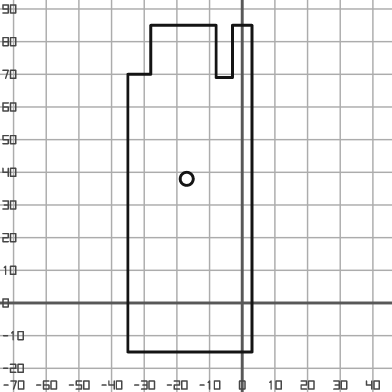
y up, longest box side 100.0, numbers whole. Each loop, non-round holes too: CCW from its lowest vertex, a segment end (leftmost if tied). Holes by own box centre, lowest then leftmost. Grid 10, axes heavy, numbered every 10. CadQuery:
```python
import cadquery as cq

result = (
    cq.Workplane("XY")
    .moveTo(-35.0, -15.0)
    .lineTo(3.0, -15.0)
    .lineTo(3.0, 85.0)
    .lineTo(-3.0, 85.0)
    .lineTo(-3.0, 69.0)
    .lineTo(-8.0, 69.0)
    .lineTo(-8.0, 85.0)
    .lineTo(-28.0, 85.0)
    .lineTo(-28.0, 70.0)
    .lineTo(-35.0, 70.0)
    .close()
    .moveTo(-17.0, 38.0)
    .circle(2.0)
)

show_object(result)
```